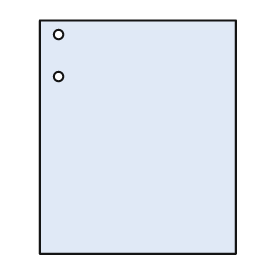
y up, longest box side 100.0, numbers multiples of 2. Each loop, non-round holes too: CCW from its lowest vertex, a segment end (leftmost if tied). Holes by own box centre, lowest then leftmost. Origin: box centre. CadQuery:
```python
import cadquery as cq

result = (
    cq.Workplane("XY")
    .moveTo(-42.0, -50.0)
    .lineTo(42.0, -50.0)
    .lineTo(42.0, 50.0)
    .lineTo(-42.0, 50.0)
    .close()
    .moveTo(-34.0, 26.0)
    .circle(2.0)
    .moveTo(-34.0, 44.0)
    .circle(2.0)
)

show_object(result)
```